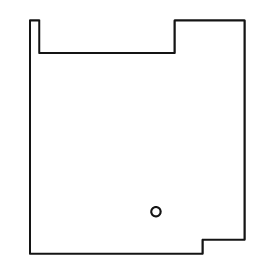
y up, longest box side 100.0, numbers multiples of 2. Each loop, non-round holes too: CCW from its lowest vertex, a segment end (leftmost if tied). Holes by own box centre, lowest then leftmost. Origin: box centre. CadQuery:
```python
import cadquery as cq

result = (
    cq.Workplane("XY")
    .moveTo(-46.0, -50.0)
    .lineTo(28.0, -50.0)
    .lineTo(28.0, -44.0)
    .lineTo(46.0, -44.0)
    .lineTo(46.0, 50.0)
    .lineTo(16.0, 50.0)
    .lineTo(16.0, 36.0)
    .lineTo(-42.0, 36.0)
    .lineTo(-42.0, 50.0)
    .lineTo(-46.0, 50.0)
    .close()
    .moveTo(8.0, -32.0)
    .circle(2.0)
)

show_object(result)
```